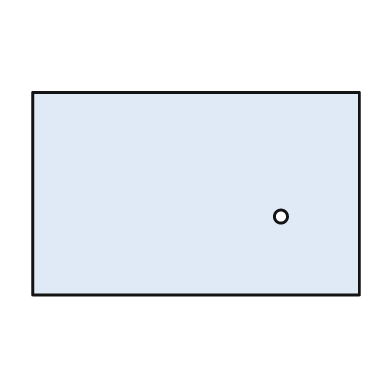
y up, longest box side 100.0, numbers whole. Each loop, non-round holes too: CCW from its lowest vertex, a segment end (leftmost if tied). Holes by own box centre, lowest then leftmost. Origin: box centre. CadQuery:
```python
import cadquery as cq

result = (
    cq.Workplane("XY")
    .moveTo(-50.0, -31.0)
    .lineTo(50.0, -31.0)
    .lineTo(50.0, 31.0)
    .lineTo(-50.0, 31.0)
    .close()
    .moveTo(26.0, -7.0)
    .circle(2.0)
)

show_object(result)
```